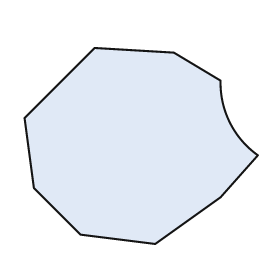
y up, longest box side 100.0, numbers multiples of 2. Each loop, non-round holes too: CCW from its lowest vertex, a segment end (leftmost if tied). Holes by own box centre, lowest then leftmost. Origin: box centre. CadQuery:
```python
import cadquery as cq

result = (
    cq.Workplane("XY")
    .moveTo(6.0, -42.0)
    .lineTo(34.0, -22.0)
    .lineTo(50.0, -4.0)
    .threePointArc((38.0, 10.0), (34.0, 28.0))
    .lineTo(14.0, 40.0)
    .lineTo(-20.0, 42.0)
    .lineTo(-50.0, 12.0)
    .lineTo(-46.0, -18.0)
    .lineTo(-26.0, -38.0)
    .close()
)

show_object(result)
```